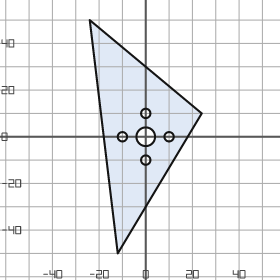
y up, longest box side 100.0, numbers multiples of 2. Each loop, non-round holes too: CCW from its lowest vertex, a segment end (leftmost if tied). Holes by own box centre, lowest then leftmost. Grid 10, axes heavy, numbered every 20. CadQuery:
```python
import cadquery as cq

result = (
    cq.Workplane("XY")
    .moveTo(-12.0, -50.0)
    .lineTo(24.0, 10.0)
    .lineTo(-24.0, 50.0)
    .close()
    .moveTo(0.0, -10.0)
    .circle(2.0)
    .moveTo(-10.0, 0.0)
    .circle(2.0)
    .moveTo(0.0, 0.0)
    .circle(4.0)
    .moveTo(10.0, 0.0)
    .circle(2.0)
    .moveTo(0.0, 10.0)
    .circle(2.0)
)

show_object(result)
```